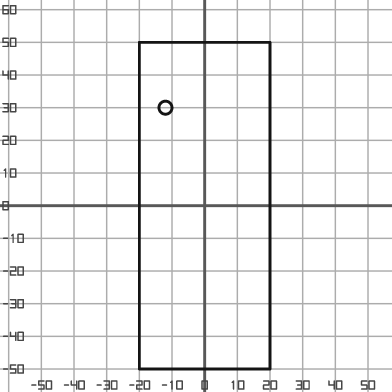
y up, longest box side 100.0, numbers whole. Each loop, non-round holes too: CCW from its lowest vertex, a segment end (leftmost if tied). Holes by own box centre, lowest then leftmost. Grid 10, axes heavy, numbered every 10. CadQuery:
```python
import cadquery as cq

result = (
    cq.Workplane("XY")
    .moveTo(-20.0, -50.0)
    .lineTo(20.0, -50.0)
    .lineTo(20.0, 50.0)
    .lineTo(-20.0, 50.0)
    .close()
    .moveTo(-12.0, 30.0)
    .circle(2.0)
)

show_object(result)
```